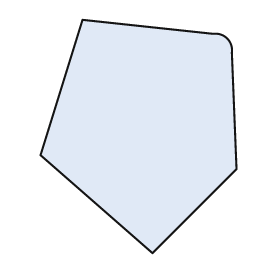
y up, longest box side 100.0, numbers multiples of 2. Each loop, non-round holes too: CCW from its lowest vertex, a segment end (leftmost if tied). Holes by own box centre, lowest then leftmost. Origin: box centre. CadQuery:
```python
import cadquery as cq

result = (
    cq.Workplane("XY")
    .moveTo(6.0, -50.0)
    .lineTo(42.0, -14.0)
    .lineTo(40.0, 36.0)
    .threePointArc((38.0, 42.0), (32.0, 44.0))
    .lineTo(-24.0, 50.0)
    .lineTo(-42.0, -8.0)
    .close()
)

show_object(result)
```